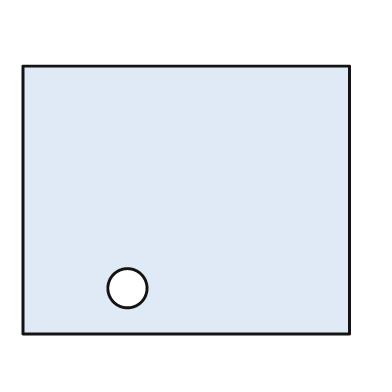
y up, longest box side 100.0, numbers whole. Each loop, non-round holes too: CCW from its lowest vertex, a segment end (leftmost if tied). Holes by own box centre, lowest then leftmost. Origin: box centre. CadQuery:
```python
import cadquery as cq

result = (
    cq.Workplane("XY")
    .moveTo(-50.0, -41.0)
    .lineTo(50.0, -41.0)
    .lineTo(50.0, 41.0)
    .lineTo(-50.0, 41.0)
    .close()
    .moveTo(-18.0, -27.0)
    .circle(6.0)
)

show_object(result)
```